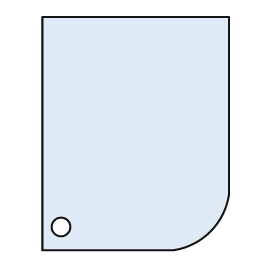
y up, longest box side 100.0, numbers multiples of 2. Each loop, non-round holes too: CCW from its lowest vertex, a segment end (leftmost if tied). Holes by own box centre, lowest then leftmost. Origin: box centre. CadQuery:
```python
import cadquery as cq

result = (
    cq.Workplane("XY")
    .moveTo(-40.0, -50.0)
    .lineTo(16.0, -50.0)
    .threePointArc((32.0, -42.0), (40.0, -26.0))
    .lineTo(40.0, 50.0)
    .lineTo(-40.0, 50.0)
    .close()
    .moveTo(-32.0, -40.0)
    .circle(4.0)
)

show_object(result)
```